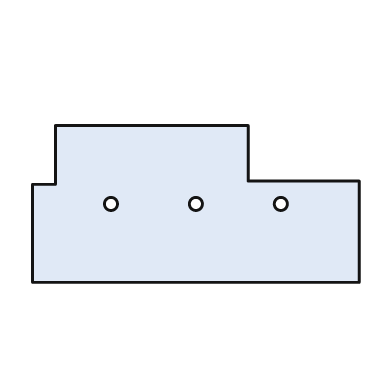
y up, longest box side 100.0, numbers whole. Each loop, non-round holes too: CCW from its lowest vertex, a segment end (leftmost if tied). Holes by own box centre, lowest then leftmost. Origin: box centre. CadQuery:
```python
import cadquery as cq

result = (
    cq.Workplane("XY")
    .moveTo(-50.0, -24.0)
    .lineTo(50.0, -24.0)
    .lineTo(50.0, 7.0)
    .lineTo(16.0, 7.0)
    .lineTo(16.0, 24.0)
    .lineTo(-43.0, 24.0)
    .lineTo(-43.0, 6.0)
    .lineTo(-50.0, 6.0)
    .close()
    .moveTo(-26.0, 0.0)
    .circle(2.0)
    .moveTo(0.0, 0.0)
    .circle(2.0)
    .moveTo(26.0, 0.0)
    .circle(2.0)
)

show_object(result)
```